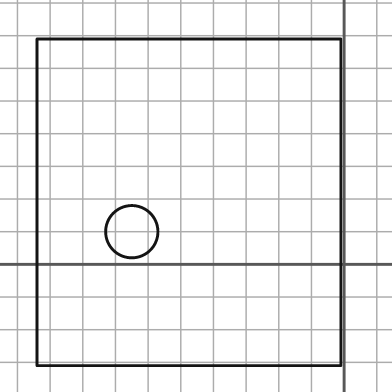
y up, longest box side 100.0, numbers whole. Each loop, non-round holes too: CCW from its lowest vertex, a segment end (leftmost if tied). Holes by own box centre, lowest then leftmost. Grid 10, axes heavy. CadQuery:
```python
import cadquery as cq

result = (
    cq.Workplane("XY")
    .moveTo(-94.0, -31.0)
    .lineTo(-1.0, -31.0)
    .lineTo(-1.0, 69.0)
    .lineTo(-94.0, 69.0)
    .close()
    .moveTo(-65.0, 10.0)
    .circle(8.0)
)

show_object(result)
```